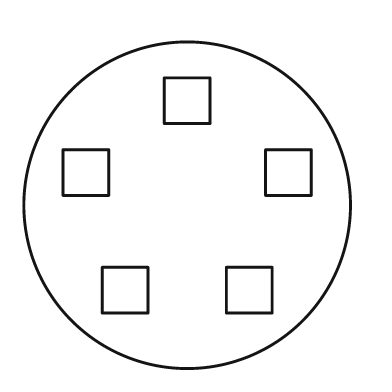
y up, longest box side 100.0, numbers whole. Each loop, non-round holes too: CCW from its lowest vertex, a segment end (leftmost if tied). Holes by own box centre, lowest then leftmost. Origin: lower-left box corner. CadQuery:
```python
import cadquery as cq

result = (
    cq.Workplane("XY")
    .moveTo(50.0, 50.0)
    .circle(50.0)
    .moveTo(24.0, 17.0)
    .lineTo(38.0, 17.0)
    .lineTo(38.0, 31.0)
    .lineTo(24.0, 31.0)
    .close()
    .moveTo(62.0, 17.0)
    .lineTo(76.0, 17.0)
    .lineTo(76.0, 31.0)
    .lineTo(62.0, 31.0)
    .close()
    .moveTo(12.0, 53.0)
    .lineTo(26.0, 53.0)
    .lineTo(26.0, 67.0)
    .lineTo(12.0, 67.0)
    .close()
    .moveTo(74.0, 53.0)
    .lineTo(88.0, 53.0)
    .lineTo(88.0, 67.0)
    .lineTo(74.0, 67.0)
    .close()
    .moveTo(43.0, 75.0)
    .lineTo(57.0, 75.0)
    .lineTo(57.0, 89.0)
    .lineTo(43.0, 89.0)
    .close()
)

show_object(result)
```